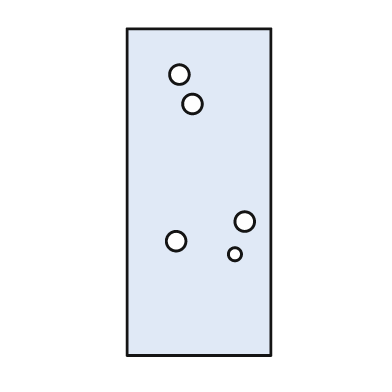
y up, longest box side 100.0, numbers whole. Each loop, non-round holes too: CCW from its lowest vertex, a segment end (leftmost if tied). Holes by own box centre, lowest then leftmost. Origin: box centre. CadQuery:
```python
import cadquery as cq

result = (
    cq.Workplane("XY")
    .moveTo(-22.0, -50.0)
    .lineTo(22.0, -50.0)
    .lineTo(22.0, 50.0)
    .lineTo(-22.0, 50.0)
    .close()
    .moveTo(11.0, -19.0)
    .circle(2.0)
    .moveTo(-7.0, -15.0)
    .circle(3.0)
    .moveTo(14.0, -9.0)
    .circle(3.0)
    .moveTo(-2.0, 27.0)
    .circle(3.0)
    .moveTo(-6.0, 36.0)
    .circle(3.0)
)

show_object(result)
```